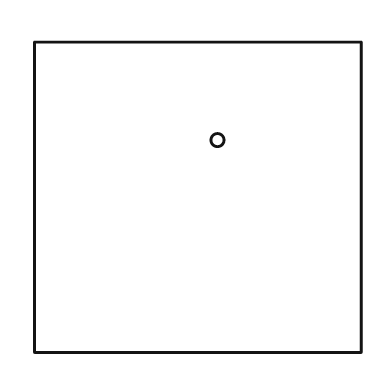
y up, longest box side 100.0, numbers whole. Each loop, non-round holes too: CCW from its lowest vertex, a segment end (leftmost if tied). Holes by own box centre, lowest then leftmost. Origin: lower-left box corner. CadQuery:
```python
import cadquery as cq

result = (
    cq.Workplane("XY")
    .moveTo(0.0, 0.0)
    .lineTo(100.0, 0.0)
    .lineTo(100.0, 95.0)
    .lineTo(0.0, 95.0)
    .close()
    .moveTo(56.0, 65.0)
    .circle(2.0)
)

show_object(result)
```